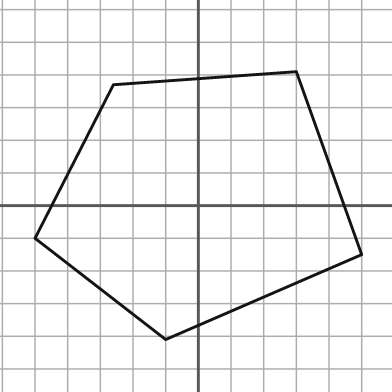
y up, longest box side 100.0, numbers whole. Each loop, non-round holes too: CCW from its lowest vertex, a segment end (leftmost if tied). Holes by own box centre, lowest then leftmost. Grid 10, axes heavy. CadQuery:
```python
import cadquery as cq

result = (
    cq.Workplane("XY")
    .moveTo(-10.0, -41.0)
    .lineTo(50.0, -15.0)
    .lineTo(30.0, 41.0)
    .lineTo(-26.0, 37.0)
    .lineTo(-50.0, -10.0)
    .close()
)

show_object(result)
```